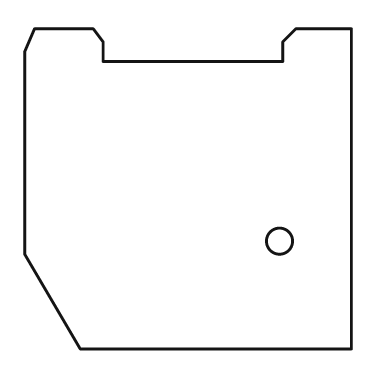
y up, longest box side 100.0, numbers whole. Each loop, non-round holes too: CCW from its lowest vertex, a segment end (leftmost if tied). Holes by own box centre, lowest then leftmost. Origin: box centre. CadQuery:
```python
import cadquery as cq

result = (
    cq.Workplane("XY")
    .moveTo(-33.0, -49.0)
    .lineTo(50.0, -49.0)
    .lineTo(50.0, 49.0)
    .lineTo(33.0, 49.0)
    .lineTo(29.0, 45.0)
    .lineTo(29.0, 39.0)
    .lineTo(-26.0, 39.0)
    .lineTo(-26.0, 45.0)
    .lineTo(-29.0, 49.0)
    .lineTo(-47.0, 49.0)
    .lineTo(-50.0, 42.0)
    .lineTo(-50.0, -20.0)
    .close()
    .moveTo(28.0, -16.0)
    .circle(4.0)
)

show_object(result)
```